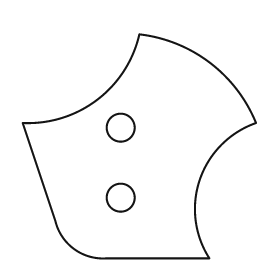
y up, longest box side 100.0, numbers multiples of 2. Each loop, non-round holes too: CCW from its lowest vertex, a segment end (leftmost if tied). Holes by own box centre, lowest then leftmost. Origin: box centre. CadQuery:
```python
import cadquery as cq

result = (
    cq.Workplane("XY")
    .moveTo(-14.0, -48.0)
    .lineTo(30.0, -48.0)
    .threePointArc((26.0, -14.0), (50.0, 10.0))
    .threePointArc((30.0, 36.0), (0.0, 48.0))
    .threePointArc((-18.0, 20.0), (-50.0, 10.0))
    .lineTo(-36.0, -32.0)
    .threePointArc((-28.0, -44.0), (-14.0, -48.0))
    .close()
    .moveTo(-8.0, -22.0)
    .circle(6.0)
    .moveTo(-8.0, 8.0)
    .circle(6.0)
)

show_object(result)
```